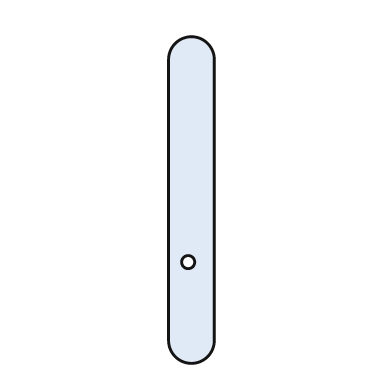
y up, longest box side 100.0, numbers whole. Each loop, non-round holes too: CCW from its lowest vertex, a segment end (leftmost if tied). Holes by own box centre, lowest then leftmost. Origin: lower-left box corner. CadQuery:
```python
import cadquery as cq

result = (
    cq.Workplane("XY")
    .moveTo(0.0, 7.0)
    .threePointArc((7.0, 0.0), (14.0, 7.0))
    .lineTo(14.0, 93.0)
    .threePointArc((7.0, 100.0), (0.0, 93.0))
    .close()
    .moveTo(6.0, 31.0)
    .circle(2.0)
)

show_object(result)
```